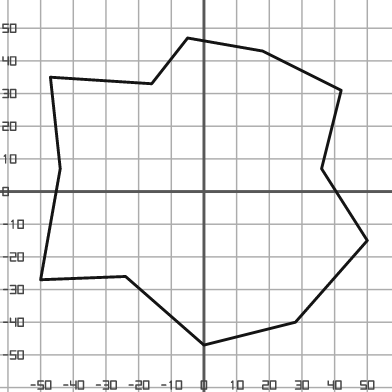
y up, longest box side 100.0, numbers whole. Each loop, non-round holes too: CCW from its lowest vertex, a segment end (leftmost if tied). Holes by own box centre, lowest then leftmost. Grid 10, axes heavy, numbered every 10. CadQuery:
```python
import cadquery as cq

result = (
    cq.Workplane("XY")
    .moveTo(0.0, -47.0)
    .lineTo(28.0, -40.0)
    .lineTo(50.0, -15.0)
    .lineTo(36.0, 7.0)
    .lineTo(42.0, 31.0)
    .lineTo(18.0, 43.0)
    .lineTo(-5.0, 47.0)
    .lineTo(-16.0, 33.0)
    .lineTo(-47.0, 35.0)
    .lineTo(-44.0, 7.0)
    .lineTo(-50.0, -27.0)
    .lineTo(-24.0, -26.0)
    .close()
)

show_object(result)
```